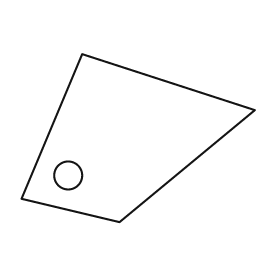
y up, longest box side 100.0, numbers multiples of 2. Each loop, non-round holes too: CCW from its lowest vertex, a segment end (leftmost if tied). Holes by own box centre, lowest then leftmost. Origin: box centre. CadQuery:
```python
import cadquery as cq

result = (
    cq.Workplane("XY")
    .moveTo(-8.0, -36.0)
    .lineTo(50.0, 12.0)
    .lineTo(-24.0, 36.0)
    .lineTo(-50.0, -26.0)
    .close()
    .moveTo(-30.0, -16.0)
    .circle(6.0)
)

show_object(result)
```